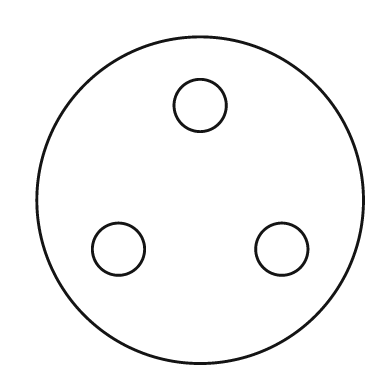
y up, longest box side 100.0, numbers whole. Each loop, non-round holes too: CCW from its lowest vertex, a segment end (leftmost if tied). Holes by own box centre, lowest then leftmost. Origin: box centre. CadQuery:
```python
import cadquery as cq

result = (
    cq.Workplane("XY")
    .moveTo(0.0, 0.0)
    .circle(50.0)
    .moveTo(-25.0, -15.0)
    .circle(8.0)
    .moveTo(25.0, -15.0)
    .circle(8.0)
    .moveTo(0.0, 29.0)
    .circle(8.0)
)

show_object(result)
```